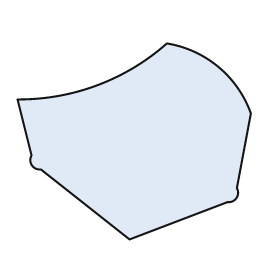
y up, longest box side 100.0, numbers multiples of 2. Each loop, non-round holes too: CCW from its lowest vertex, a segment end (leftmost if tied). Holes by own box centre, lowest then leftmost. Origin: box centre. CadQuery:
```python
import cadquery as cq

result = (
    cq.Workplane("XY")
    .moveTo(-2.0, -42.0)
    .lineTo(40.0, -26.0)
    .threePointArc((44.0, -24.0), (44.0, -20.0))
    .lineTo(50.0, 12.0)
    .threePointArc((36.0, 32.0), (14.0, 42.0))
    .threePointArc((-16.0, 24.0), (-50.0, 18.0))
    .lineTo(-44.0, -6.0)
    .threePointArc((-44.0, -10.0), (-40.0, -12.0))
    .close()
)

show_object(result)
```